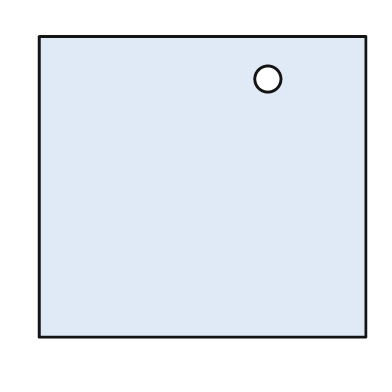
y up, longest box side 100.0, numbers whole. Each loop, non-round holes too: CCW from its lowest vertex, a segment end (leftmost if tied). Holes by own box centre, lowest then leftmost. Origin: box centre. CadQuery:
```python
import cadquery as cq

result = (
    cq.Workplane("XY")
    .moveTo(-50.0, -46.0)
    .lineTo(50.0, -46.0)
    .lineTo(50.0, 46.0)
    .lineTo(-50.0, 46.0)
    .close()
    .moveTo(20.0, 33.0)
    .circle(4.0)
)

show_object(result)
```